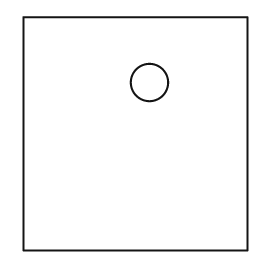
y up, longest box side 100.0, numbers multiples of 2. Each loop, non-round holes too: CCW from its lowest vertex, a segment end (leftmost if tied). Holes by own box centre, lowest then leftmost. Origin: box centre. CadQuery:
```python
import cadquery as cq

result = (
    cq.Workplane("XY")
    .moveTo(-48.0, -50.0)
    .lineTo(48.0, -50.0)
    .lineTo(48.0, 50.0)
    .lineTo(-48.0, 50.0)
    .close()
    .moveTo(6.0, 22.0)
    .circle(8.0)
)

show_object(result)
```